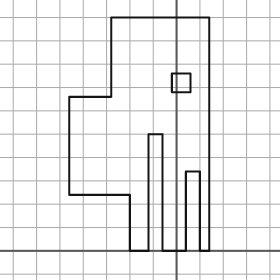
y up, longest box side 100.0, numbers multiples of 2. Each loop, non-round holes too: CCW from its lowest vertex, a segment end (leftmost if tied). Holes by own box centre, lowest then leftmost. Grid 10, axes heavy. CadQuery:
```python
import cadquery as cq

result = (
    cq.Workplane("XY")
    .moveTo(-20.0, 0.0)
    .lineTo(-12.0, 0.0)
    .lineTo(-12.0, 50.0)
    .lineTo(-6.0, 50.0)
    .lineTo(-6.0, 0.0)
    .lineTo(4.0, 0.0)
    .lineTo(4.0, 34.0)
    .lineTo(10.0, 34.0)
    .lineTo(10.0, 0.0)
    .lineTo(14.0, 0.0)
    .lineTo(14.0, 100.0)
    .lineTo(-28.0, 100.0)
    .lineTo(-28.0, 66.0)
    .lineTo(-46.0, 66.0)
    .lineTo(-46.0, 24.0)
    .lineTo(-20.0, 24.0)
    .close()
    .moveTo(-2.0, 68.0)
    .lineTo(6.0, 68.0)
    .lineTo(6.0, 76.0)
    .lineTo(-2.0, 76.0)
    .close()
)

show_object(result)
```